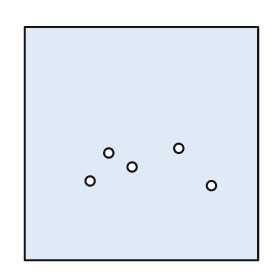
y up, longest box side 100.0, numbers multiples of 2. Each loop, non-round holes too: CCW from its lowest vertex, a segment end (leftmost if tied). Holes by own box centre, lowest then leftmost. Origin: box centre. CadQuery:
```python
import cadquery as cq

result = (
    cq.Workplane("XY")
    .moveTo(-50.0, -50.0)
    .lineTo(50.0, -50.0)
    .lineTo(50.0, 50.0)
    .lineTo(-50.0, 50.0)
    .close()
    .moveTo(30.0, -18.0)
    .circle(2.0)
    .moveTo(-22.0, -16.0)
    .circle(2.0)
    .moveTo(-4.0, -10.0)
    .circle(2.0)
    .moveTo(-14.0, -4.0)
    .circle(2.0)
    .moveTo(16.0, -2.0)
    .circle(2.0)
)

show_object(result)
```